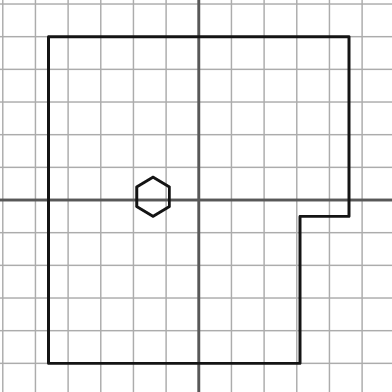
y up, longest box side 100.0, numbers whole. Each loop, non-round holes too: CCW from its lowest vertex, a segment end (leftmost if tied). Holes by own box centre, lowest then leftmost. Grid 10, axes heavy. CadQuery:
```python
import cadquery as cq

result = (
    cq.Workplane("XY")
    .moveTo(-46.0, -50.0)
    .lineTo(31.0, -50.0)
    .lineTo(31.0, -5.0)
    .lineTo(46.0, -5.0)
    .lineTo(46.0, 50.0)
    .lineTo(-46.0, 50.0)
    .close()
    .moveTo(-14.0, -5.0)
    .lineTo(-9.0, -2.0)
    .lineTo(-9.0, 4.0)
    .lineTo(-14.0, 7.0)
    .lineTo(-19.0, 4.0)
    .lineTo(-19.0, -2.0)
    .close()
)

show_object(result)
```